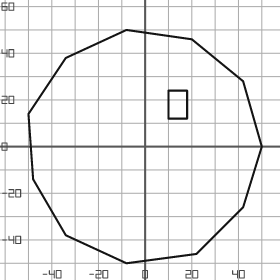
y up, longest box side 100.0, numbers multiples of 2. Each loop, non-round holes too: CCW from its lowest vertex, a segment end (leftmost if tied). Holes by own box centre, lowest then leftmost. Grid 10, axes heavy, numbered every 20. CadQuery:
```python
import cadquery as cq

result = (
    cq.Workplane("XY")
    .moveTo(-8.0, -50.0)
    .lineTo(22.0, -46.0)
    .lineTo(42.0, -26.0)
    .lineTo(50.0, 0.0)
    .lineTo(42.0, 28.0)
    .lineTo(20.0, 46.0)
    .lineTo(-8.0, 50.0)
    .lineTo(-34.0, 38.0)
    .lineTo(-50.0, 14.0)
    .lineTo(-48.0, -14.0)
    .lineTo(-34.0, -38.0)
    .close()
    .moveTo(10.0, 12.0)
    .lineTo(18.0, 12.0)
    .lineTo(18.0, 24.0)
    .lineTo(10.0, 24.0)
    .close()
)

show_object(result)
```